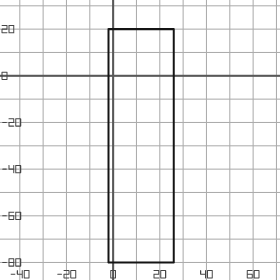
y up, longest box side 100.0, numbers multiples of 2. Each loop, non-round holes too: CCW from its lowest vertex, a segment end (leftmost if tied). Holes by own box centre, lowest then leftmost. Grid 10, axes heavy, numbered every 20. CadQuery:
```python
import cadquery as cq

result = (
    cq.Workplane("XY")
    .moveTo(-2.0, -80.0)
    .lineTo(26.0, -80.0)
    .lineTo(26.0, 20.0)
    .lineTo(-2.0, 20.0)
    .close()
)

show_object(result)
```